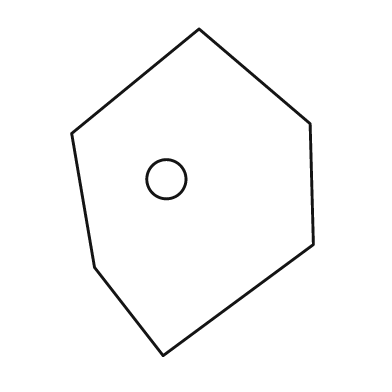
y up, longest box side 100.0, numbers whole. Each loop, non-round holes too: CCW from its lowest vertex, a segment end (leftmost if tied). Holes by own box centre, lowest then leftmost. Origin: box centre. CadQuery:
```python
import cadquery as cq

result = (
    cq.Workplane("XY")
    .moveTo(-9.0, -50.0)
    .lineTo(37.0, -16.0)
    .lineTo(36.0, 21.0)
    .lineTo(2.0, 50.0)
    .lineTo(-37.0, 18.0)
    .lineTo(-30.0, -23.0)
    .close()
    .moveTo(-8.0, 4.0)
    .circle(6.0)
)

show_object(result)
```